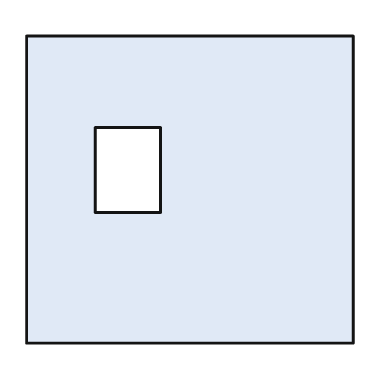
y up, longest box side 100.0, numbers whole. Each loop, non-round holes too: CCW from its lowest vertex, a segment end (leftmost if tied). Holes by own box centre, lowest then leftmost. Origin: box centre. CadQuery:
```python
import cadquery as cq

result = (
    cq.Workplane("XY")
    .moveTo(-50.0, -47.0)
    .lineTo(50.0, -47.0)
    .lineTo(50.0, 47.0)
    .lineTo(-50.0, 47.0)
    .close()
    .moveTo(-29.0, -7.0)
    .lineTo(-9.0, -7.0)
    .lineTo(-9.0, 19.0)
    .lineTo(-29.0, 19.0)
    .close()
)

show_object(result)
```